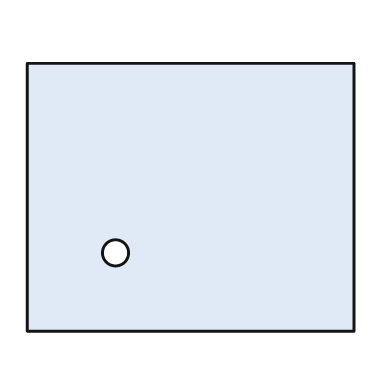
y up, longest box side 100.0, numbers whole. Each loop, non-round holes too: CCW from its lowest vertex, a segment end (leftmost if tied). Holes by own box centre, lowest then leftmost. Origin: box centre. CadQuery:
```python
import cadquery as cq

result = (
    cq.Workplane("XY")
    .moveTo(-50.0, -41.0)
    .lineTo(50.0, -41.0)
    .lineTo(50.0, 41.0)
    .lineTo(-50.0, 41.0)
    .close()
    .moveTo(-23.0, -17.0)
    .circle(4.0)
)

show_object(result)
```